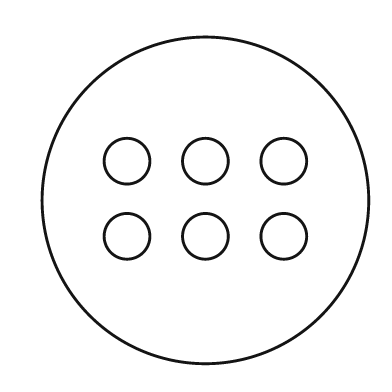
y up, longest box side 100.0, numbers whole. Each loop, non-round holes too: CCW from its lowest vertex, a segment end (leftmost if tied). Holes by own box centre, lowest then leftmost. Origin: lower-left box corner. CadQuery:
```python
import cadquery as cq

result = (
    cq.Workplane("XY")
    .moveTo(50.0, 50.0)
    .circle(50.0)
    .moveTo(26.0, 39.0)
    .circle(7.0)
    .moveTo(50.0, 39.0)
    .circle(7.0)
    .moveTo(74.0, 39.0)
    .circle(7.0)
    .moveTo(26.0, 62.0)
    .circle(7.0)
    .moveTo(50.0, 62.0)
    .circle(7.0)
    .moveTo(74.0, 62.0)
    .circle(7.0)
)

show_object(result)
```